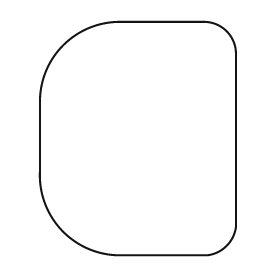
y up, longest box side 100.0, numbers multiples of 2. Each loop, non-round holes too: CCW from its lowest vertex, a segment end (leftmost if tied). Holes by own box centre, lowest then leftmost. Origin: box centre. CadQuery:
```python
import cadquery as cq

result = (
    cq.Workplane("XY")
    .moveTo(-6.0, -50.0)
    .lineTo(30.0, -50.0)
    .threePointArc((38.0, -46.0), (42.0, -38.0))
    .lineTo(42.0, 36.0)
    .threePointArc((38.0, 46.0), (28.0, 50.0))
    .lineTo(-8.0, 50.0)
    .threePointArc((-32.0, 40.0), (-42.0, 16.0))
    .lineTo(-42.0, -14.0)
    .threePointArc((-32.0, -40.0), (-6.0, -50.0))
    .close()
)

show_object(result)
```